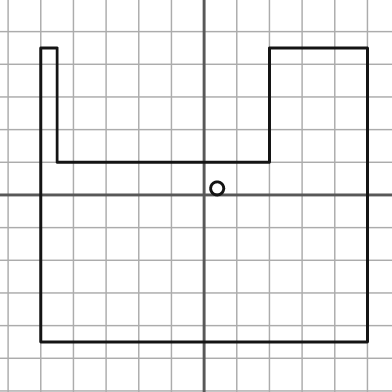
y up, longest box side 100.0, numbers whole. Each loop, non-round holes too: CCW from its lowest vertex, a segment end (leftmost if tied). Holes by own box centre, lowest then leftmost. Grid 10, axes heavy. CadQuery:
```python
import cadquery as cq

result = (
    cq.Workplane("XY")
    .moveTo(-50.0, -45.0)
    .lineTo(50.0, -45.0)
    .lineTo(50.0, 45.0)
    .lineTo(20.0, 45.0)
    .lineTo(20.0, 10.0)
    .lineTo(-45.0, 10.0)
    .lineTo(-45.0, 45.0)
    .lineTo(-50.0, 45.0)
    .close()
    .moveTo(4.0, 2.0)
    .circle(2.0)
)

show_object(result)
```